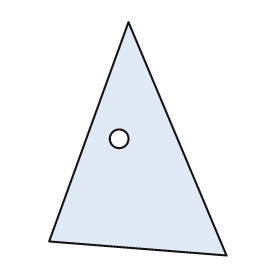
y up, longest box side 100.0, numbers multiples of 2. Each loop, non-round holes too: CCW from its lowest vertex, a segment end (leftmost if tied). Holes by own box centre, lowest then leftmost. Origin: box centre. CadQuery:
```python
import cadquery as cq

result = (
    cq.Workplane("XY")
    .moveTo(38.0, -50.0)
    .lineTo(-4.0, 50.0)
    .lineTo(-38.0, -44.0)
    .close()
    .moveTo(-8.0, 0.0)
    .circle(4.0)
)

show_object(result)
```